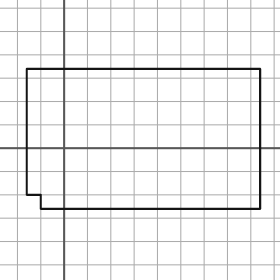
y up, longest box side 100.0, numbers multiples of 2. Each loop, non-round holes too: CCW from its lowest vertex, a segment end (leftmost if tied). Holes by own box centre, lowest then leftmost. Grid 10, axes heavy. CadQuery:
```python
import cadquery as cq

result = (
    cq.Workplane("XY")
    .moveTo(-10.0, -26.0)
    .lineTo(84.0, -26.0)
    .lineTo(84.0, 34.0)
    .lineTo(-16.0, 34.0)
    .lineTo(-16.0, -20.0)
    .lineTo(-10.0, -20.0)
    .close()
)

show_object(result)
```